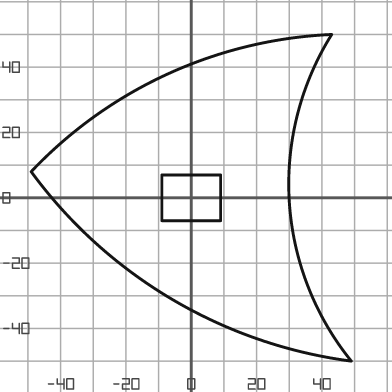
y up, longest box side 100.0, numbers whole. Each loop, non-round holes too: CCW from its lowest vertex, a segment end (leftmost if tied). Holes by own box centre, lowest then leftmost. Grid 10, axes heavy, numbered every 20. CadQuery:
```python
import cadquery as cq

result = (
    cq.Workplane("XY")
    .moveTo(49.0, -50.0)
    .threePointArc((30.0, -1.0), (43.0, 50.0))
    .threePointArc((-7.0, 38.0), (-49.0, 8.0))
    .threePointArc((-6.0, -31.0), (49.0, -50.0))
    .close()
    .moveTo(-9.0, -7.0)
    .lineTo(9.0, -7.0)
    .lineTo(9.0, 7.0)
    .lineTo(-9.0, 7.0)
    .close()
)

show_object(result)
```